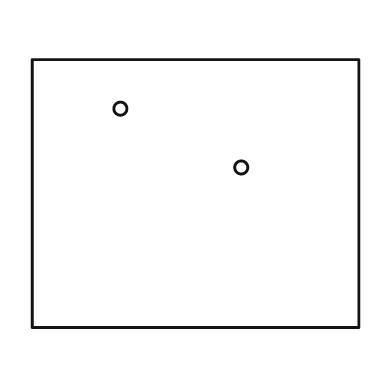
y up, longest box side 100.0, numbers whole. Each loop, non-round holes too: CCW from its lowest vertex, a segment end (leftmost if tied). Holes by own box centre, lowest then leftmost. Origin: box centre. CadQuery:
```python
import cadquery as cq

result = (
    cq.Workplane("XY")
    .moveTo(-50.0, -41.0)
    .lineTo(50.0, -41.0)
    .lineTo(50.0, 41.0)
    .lineTo(-50.0, 41.0)
    .close()
    .moveTo(14.0, 8.0)
    .circle(2.0)
    .moveTo(-23.0, 26.0)
    .circle(2.0)
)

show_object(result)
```